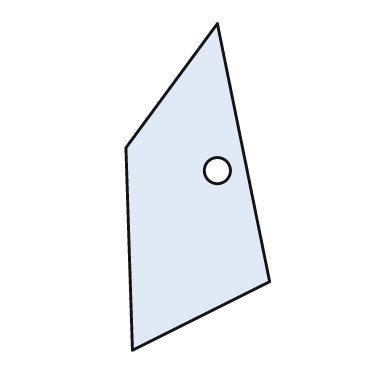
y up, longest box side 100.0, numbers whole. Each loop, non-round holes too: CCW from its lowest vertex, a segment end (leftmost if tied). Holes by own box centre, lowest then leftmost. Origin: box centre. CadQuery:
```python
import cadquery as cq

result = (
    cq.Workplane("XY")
    .moveTo(-20.0, -50.0)
    .lineTo(22.0, -29.0)
    .lineTo(6.0, 50.0)
    .lineTo(-22.0, 12.0)
    .close()
    .moveTo(6.0, 5.0)
    .circle(4.0)
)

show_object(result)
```